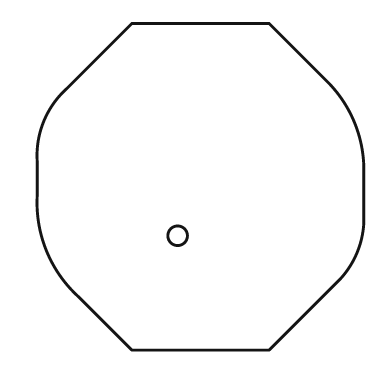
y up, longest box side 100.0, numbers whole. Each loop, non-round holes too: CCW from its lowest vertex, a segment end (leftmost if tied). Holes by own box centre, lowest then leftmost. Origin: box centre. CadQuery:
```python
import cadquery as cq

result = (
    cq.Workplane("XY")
    .moveTo(-21.0, -50.0)
    .lineTo(21.0, -50.0)
    .lineTo(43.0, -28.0)
    .threePointArc((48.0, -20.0), (50.0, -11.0))
    .lineTo(50.0, 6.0)
    .threePointArc((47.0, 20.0), (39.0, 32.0))
    .lineTo(21.0, 50.0)
    .lineTo(-21.0, 50.0)
    .lineTo(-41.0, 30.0)
    .threePointArc((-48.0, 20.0), (-50.0, 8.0))
    .lineTo(-50.0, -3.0)
    .threePointArc((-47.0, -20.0), (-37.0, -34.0))
    .close()
    .moveTo(-7.0, -15.0)
    .circle(3.0)
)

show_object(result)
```